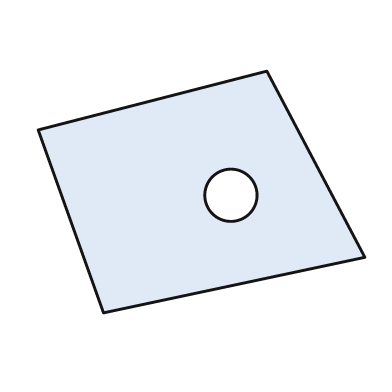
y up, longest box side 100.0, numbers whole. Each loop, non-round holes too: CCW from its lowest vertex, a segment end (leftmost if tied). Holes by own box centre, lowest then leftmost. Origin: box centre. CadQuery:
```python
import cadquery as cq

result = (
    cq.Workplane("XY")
    .moveTo(-30.0, -37.0)
    .lineTo(50.0, -20.0)
    .lineTo(20.0, 37.0)
    .lineTo(-50.0, 19.0)
    .close()
    .moveTo(9.0, -1.0)
    .circle(8.0)
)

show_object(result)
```